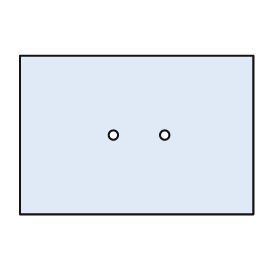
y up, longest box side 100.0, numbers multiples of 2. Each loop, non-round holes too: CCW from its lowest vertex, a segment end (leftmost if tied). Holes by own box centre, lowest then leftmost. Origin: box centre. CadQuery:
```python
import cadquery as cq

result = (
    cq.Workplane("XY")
    .moveTo(-50.0, -34.0)
    .lineTo(50.0, -34.0)
    .lineTo(50.0, 34.0)
    .lineTo(-50.0, 34.0)
    .close()
    .moveTo(-10.0, 0.0)
    .circle(2.0)
    .moveTo(12.0, 0.0)
    .circle(2.0)
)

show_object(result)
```